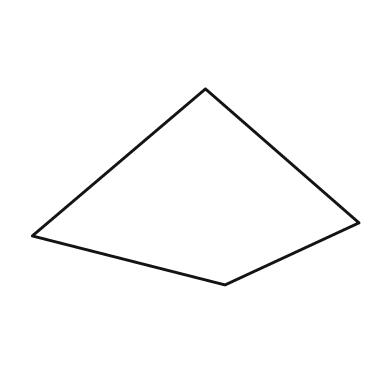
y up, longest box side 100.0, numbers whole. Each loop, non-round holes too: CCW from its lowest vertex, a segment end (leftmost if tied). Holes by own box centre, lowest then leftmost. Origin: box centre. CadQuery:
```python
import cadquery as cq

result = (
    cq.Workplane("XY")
    .moveTo(9.0, -30.0)
    .lineTo(50.0, -11.0)
    .lineTo(3.0, 30.0)
    .lineTo(-50.0, -15.0)
    .close()
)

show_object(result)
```